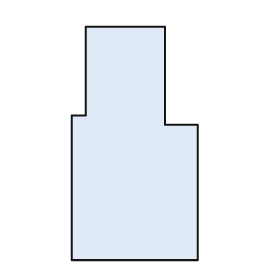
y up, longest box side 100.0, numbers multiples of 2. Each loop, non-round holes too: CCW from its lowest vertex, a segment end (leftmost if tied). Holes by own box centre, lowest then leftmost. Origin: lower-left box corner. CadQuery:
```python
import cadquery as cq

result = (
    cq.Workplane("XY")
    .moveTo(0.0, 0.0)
    .lineTo(54.0, 0.0)
    .lineTo(54.0, 58.0)
    .lineTo(40.0, 58.0)
    .lineTo(40.0, 100.0)
    .lineTo(6.0, 100.0)
    .lineTo(6.0, 62.0)
    .lineTo(0.0, 62.0)
    .close()
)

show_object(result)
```